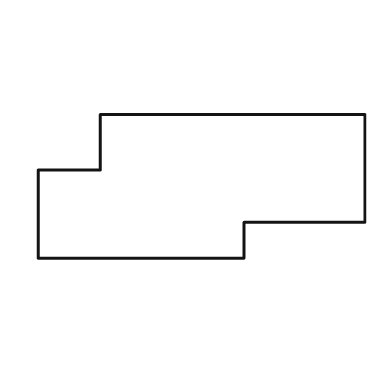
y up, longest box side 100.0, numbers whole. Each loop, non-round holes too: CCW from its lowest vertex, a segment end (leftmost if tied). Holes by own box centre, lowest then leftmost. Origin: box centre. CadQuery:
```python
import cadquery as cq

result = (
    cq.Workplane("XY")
    .moveTo(-50.0, -22.0)
    .lineTo(13.0, -22.0)
    .lineTo(13.0, -11.0)
    .lineTo(50.0, -11.0)
    .lineTo(50.0, 22.0)
    .lineTo(-31.0, 22.0)
    .lineTo(-31.0, 5.0)
    .lineTo(-50.0, 5.0)
    .close()
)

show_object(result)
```